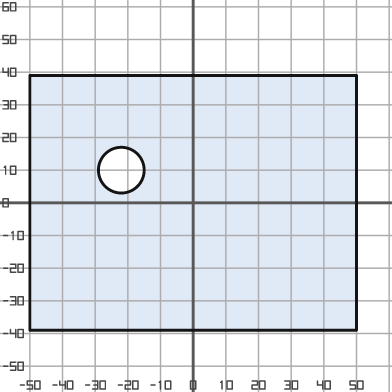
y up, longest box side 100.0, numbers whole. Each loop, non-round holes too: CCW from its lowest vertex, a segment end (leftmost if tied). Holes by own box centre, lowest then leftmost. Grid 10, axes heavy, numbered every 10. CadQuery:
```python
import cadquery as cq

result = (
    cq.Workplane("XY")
    .moveTo(-50.0, -39.0)
    .lineTo(50.0, -39.0)
    .lineTo(50.0, 39.0)
    .lineTo(-50.0, 39.0)
    .close()
    .moveTo(-22.0, 10.0)
    .circle(7.0)
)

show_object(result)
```